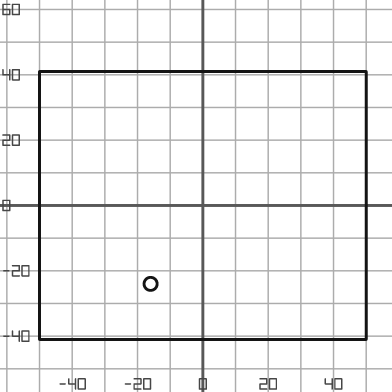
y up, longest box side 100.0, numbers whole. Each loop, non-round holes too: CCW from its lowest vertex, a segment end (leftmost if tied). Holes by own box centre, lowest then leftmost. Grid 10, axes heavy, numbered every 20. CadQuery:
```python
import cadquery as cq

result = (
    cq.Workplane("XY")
    .moveTo(-50.0, -41.0)
    .lineTo(50.0, -41.0)
    .lineTo(50.0, 41.0)
    .lineTo(-50.0, 41.0)
    .close()
    .moveTo(-16.0, -24.0)
    .circle(2.0)
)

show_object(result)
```